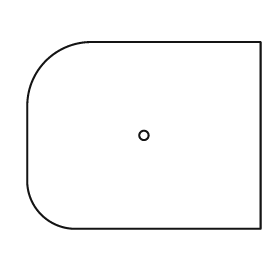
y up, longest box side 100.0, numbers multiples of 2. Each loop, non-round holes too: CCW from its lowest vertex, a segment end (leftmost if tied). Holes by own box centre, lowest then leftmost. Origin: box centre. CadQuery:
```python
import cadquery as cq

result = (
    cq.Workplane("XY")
    .moveTo(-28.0, -40.0)
    .lineTo(50.0, -40.0)
    .lineTo(50.0, 40.0)
    .lineTo(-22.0, 40.0)
    .threePointArc((-42.0, 32.0), (-50.0, 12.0))
    .lineTo(-50.0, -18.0)
    .threePointArc((-44.0, -34.0), (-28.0, -40.0))
    .close()
    .moveTo(0.0, 0.0)
    .circle(2.0)
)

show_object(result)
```